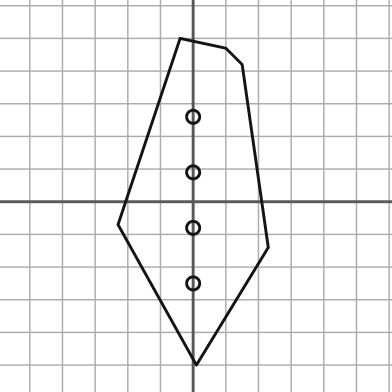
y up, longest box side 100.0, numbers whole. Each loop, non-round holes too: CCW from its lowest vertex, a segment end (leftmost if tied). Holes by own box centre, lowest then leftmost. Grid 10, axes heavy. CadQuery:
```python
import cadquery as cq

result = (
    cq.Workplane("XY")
    .moveTo(1.0, -50.0)
    .lineTo(23.0, -14.0)
    .lineTo(15.0, 42.0)
    .lineTo(10.0, 47.0)
    .lineTo(-4.0, 50.0)
    .lineTo(-23.0, -7.0)
    .close()
    .moveTo(0.0, -25.0)
    .circle(2.0)
    .moveTo(0.0, -8.0)
    .circle(2.0)
    .moveTo(0.0, 9.0)
    .circle(2.0)
    .moveTo(0.0, 26.0)
    .circle(2.0)
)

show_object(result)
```